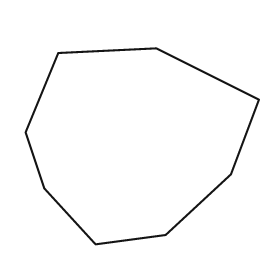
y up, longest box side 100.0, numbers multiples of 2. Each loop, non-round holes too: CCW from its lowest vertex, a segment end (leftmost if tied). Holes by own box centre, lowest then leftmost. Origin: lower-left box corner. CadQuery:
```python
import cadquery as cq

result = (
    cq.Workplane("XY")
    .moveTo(30.0, 0.0)
    .lineTo(60.0, 4.0)
    .lineTo(88.0, 30.0)
    .lineTo(100.0, 62.0)
    .lineTo(56.0, 84.0)
    .lineTo(14.0, 82.0)
    .lineTo(0.0, 48.0)
    .lineTo(8.0, 24.0)
    .close()
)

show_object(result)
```